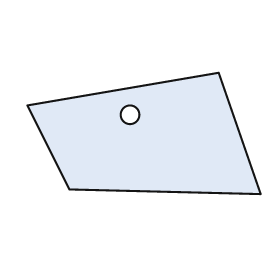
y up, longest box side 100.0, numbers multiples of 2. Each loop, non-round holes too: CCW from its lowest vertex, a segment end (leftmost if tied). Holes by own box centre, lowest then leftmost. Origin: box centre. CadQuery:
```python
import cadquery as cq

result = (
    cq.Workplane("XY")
    .moveTo(50.0, -26.0)
    .lineTo(32.0, 26.0)
    .lineTo(-50.0, 12.0)
    .lineTo(-32.0, -24.0)
    .close()
    .moveTo(-6.0, 8.0)
    .circle(4.0)
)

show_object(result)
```